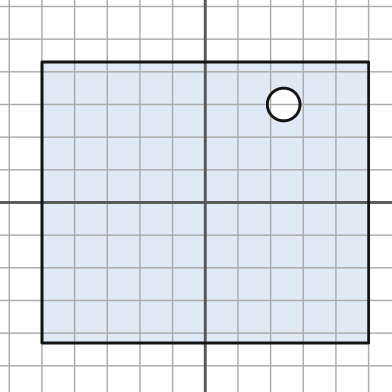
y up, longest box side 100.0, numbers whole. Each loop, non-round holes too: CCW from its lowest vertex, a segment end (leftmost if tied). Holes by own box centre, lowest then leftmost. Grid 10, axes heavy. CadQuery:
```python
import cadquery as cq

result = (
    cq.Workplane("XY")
    .moveTo(-50.0, -43.0)
    .lineTo(50.0, -43.0)
    .lineTo(50.0, 43.0)
    .lineTo(-50.0, 43.0)
    .close()
    .moveTo(24.0, 30.0)
    .circle(5.0)
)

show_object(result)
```